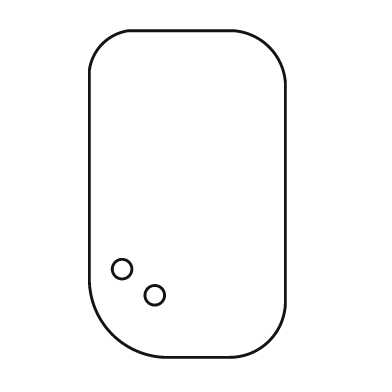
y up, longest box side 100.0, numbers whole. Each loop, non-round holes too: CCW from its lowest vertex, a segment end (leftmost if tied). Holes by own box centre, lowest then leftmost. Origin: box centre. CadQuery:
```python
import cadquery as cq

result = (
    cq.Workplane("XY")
    .moveTo(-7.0, -50.0)
    .lineTo(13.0, -50.0)
    .threePointArc((25.0, -45.0), (30.0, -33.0))
    .lineTo(30.0, 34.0)
    .threePointArc((25.0, 45.0), (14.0, 50.0))
    .lineTo(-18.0, 50.0)
    .threePointArc((-26.0, 46.0), (-30.0, 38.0))
    .lineTo(-30.0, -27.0)
    .threePointArc((-23.0, -43.0), (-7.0, -50.0))
    .close()
    .moveTo(-10.0, -31.0)
    .circle(3.0)
    .moveTo(-20.0, -23.0)
    .circle(3.0)
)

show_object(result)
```